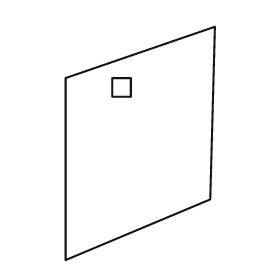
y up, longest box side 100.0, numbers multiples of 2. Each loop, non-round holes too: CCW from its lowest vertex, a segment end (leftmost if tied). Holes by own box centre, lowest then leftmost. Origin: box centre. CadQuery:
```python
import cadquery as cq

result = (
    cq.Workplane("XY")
    .moveTo(-32.0, -50.0)
    .lineTo(30.0, -24.0)
    .lineTo(32.0, 50.0)
    .lineTo(-32.0, 28.0)
    .close()
    .moveTo(-12.0, 20.0)
    .lineTo(-4.0, 20.0)
    .lineTo(-4.0, 28.0)
    .lineTo(-12.0, 28.0)
    .close()
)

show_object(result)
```